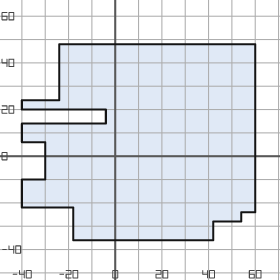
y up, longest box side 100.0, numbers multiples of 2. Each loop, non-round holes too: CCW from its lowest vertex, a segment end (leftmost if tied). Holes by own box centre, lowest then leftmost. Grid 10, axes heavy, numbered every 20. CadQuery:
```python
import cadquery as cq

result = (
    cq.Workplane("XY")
    .moveTo(-18.0, -36.0)
    .lineTo(42.0, -36.0)
    .lineTo(42.0, -28.0)
    .lineTo(54.0, -28.0)
    .lineTo(54.0, -24.0)
    .lineTo(60.0, -24.0)
    .lineTo(60.0, 48.0)
    .lineTo(-24.0, 48.0)
    .lineTo(-24.0, 24.0)
    .lineTo(-40.0, 24.0)
    .lineTo(-40.0, 20.0)
    .lineTo(-4.0, 20.0)
    .lineTo(-4.0, 14.0)
    .lineTo(-40.0, 14.0)
    .lineTo(-40.0, 6.0)
    .lineTo(-30.0, 6.0)
    .lineTo(-30.0, -10.0)
    .lineTo(-40.0, -10.0)
    .lineTo(-40.0, -22.0)
    .lineTo(-18.0, -22.0)
    .close()
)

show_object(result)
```